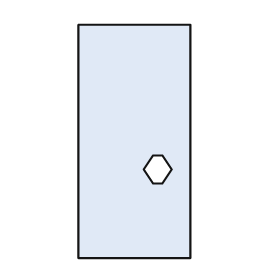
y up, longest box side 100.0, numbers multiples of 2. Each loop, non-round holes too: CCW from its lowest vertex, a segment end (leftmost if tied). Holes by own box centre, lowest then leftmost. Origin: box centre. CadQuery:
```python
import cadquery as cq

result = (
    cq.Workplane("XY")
    .moveTo(-24.0, -50.0)
    .lineTo(24.0, -50.0)
    .lineTo(24.0, 50.0)
    .lineTo(-24.0, 50.0)
    .close()
    .moveTo(8.0, -18.0)
    .lineTo(12.0, -18.0)
    .lineTo(16.0, -12.0)
    .lineTo(12.0, -6.0)
    .lineTo(8.0, -6.0)
    .lineTo(4.0, -12.0)
    .close()
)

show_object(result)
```